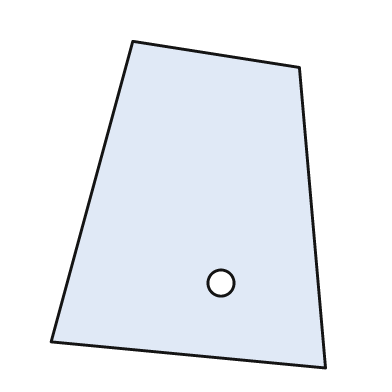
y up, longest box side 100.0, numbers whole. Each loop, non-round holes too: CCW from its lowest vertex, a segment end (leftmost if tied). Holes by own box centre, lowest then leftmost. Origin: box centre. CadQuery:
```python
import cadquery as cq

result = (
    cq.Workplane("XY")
    .moveTo(42.0, -50.0)
    .lineTo(34.0, 42.0)
    .lineTo(-17.0, 50.0)
    .lineTo(-42.0, -42.0)
    .close()
    .moveTo(10.0, -24.0)
    .circle(4.0)
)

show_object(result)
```